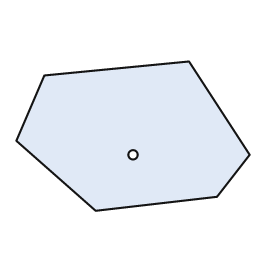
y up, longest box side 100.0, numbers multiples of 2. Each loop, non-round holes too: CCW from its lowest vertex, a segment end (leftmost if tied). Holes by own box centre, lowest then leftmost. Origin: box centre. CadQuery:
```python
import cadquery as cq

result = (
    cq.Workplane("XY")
    .moveTo(-16.0, -32.0)
    .lineTo(36.0, -26.0)
    .lineTo(50.0, -8.0)
    .lineTo(24.0, 32.0)
    .lineTo(-38.0, 26.0)
    .lineTo(-50.0, -2.0)
    .close()
    .moveTo(0.0, -8.0)
    .circle(2.0)
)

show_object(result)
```